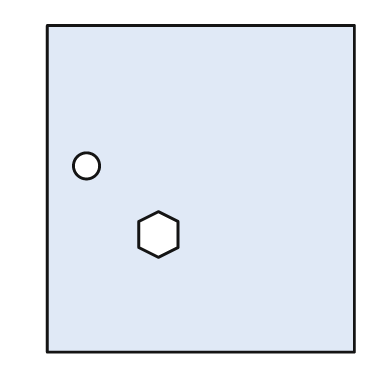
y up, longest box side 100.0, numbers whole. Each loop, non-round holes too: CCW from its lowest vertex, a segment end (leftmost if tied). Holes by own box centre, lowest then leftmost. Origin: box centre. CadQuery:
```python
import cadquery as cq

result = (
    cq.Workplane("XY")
    .moveTo(-47.0, -50.0)
    .lineTo(47.0, -50.0)
    .lineTo(47.0, 50.0)
    .lineTo(-47.0, 50.0)
    .close()
    .moveTo(-13.0, -21.0)
    .lineTo(-7.0, -18.0)
    .lineTo(-7.0, -10.0)
    .lineTo(-13.0, -7.0)
    .lineTo(-19.0, -10.0)
    .lineTo(-19.0, -18.0)
    .close()
    .moveTo(-35.0, 7.0)
    .circle(4.0)
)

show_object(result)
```